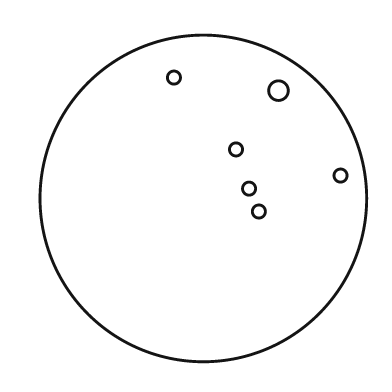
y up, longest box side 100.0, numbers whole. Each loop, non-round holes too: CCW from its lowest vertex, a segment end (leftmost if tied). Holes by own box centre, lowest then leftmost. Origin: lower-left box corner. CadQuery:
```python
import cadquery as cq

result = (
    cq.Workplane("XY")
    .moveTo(50.0, 50.0)
    .circle(50.0)
    .moveTo(67.0, 46.0)
    .circle(2.0)
    .moveTo(64.0, 53.0)
    .circle(2.0)
    .moveTo(92.0, 57.0)
    .circle(2.0)
    .moveTo(60.0, 65.0)
    .circle(2.0)
    .moveTo(73.0, 83.0)
    .circle(3.0)
    .moveTo(41.0, 87.0)
    .circle(2.0)
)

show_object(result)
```